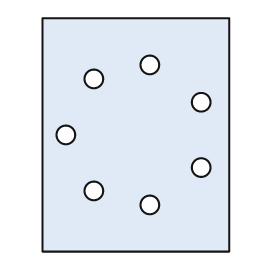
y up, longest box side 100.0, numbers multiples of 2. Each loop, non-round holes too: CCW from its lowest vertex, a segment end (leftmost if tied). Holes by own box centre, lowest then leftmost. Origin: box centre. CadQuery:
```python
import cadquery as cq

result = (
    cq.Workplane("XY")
    .moveTo(-40.0, -50.0)
    .lineTo(40.0, -50.0)
    .lineTo(40.0, 50.0)
    .lineTo(-40.0, 50.0)
    .close()
    .moveTo(6.0, -30.0)
    .circle(4.0)
    .moveTo(-18.0, -24.0)
    .circle(4.0)
    .moveTo(28.0, -14.0)
    .circle(4.0)
    .moveTo(-30.0, 0.0)
    .circle(4.0)
    .moveTo(28.0, 14.0)
    .circle(4.0)
    .moveTo(-18.0, 24.0)
    .circle(4.0)
    .moveTo(6.0, 30.0)
    .circle(4.0)
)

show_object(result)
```